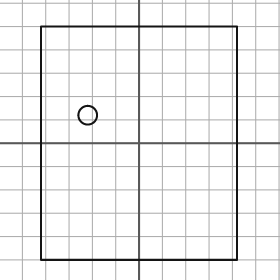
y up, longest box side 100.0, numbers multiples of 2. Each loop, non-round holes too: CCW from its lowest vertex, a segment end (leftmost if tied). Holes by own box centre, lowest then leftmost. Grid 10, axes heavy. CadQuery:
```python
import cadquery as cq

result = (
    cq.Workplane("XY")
    .moveTo(-42.0, -50.0)
    .lineTo(42.0, -50.0)
    .lineTo(42.0, 50.0)
    .lineTo(-42.0, 50.0)
    .close()
    .moveTo(-22.0, 12.0)
    .circle(4.0)
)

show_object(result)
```